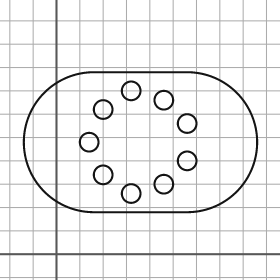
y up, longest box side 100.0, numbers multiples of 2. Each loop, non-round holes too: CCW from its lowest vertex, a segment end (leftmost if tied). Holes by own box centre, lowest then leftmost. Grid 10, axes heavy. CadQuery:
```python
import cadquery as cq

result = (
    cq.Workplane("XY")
    .moveTo(16.0, 18.0)
    .lineTo(56.0, 18.0)
    .threePointArc((86.0, 48.0), (56.0, 78.0))
    .lineTo(16.0, 78.0)
    .threePointArc((-14.0, 48.0), (16.0, 18.0))
    .close()
    .moveTo(32.0, 26.0)
    .circle(4.0)
    .moveTo(46.0, 30.0)
    .circle(4.0)
    .moveTo(20.0, 34.0)
    .circle(4.0)
    .moveTo(56.0, 40.0)
    .circle(4.0)
    .moveTo(14.0, 48.0)
    .circle(4.0)
    .moveTo(56.0, 56.0)
    .circle(4.0)
    .moveTo(20.0, 62.0)
    .circle(4.0)
    .moveTo(46.0, 66.0)
    .circle(4.0)
    .moveTo(32.0, 70.0)
    .circle(4.0)
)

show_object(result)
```